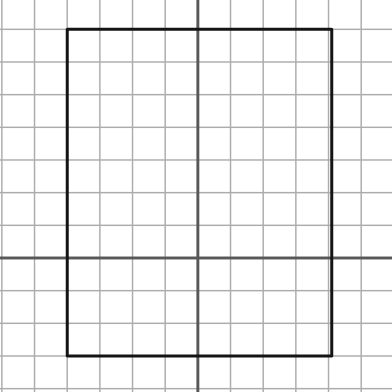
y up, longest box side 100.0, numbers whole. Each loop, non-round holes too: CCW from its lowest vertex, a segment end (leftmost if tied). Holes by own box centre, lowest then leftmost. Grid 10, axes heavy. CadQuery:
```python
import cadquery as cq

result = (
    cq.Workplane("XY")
    .moveTo(-40.0, -30.0)
    .lineTo(41.0, -30.0)
    .lineTo(41.0, 70.0)
    .lineTo(-40.0, 70.0)
    .close()
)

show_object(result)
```